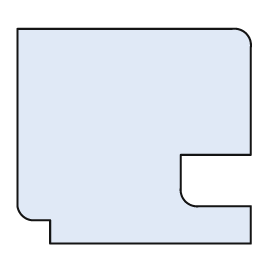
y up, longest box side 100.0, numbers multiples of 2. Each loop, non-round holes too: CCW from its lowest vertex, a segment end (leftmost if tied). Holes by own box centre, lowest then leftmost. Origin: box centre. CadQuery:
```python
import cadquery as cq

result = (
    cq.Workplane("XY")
    .moveTo(-36.0, -46.0)
    .lineTo(50.0, -46.0)
    .lineTo(50.0, -30.0)
    .lineTo(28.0, -30.0)
    .threePointArc((22.0, -28.0), (20.0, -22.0))
    .lineTo(20.0, -8.0)
    .lineTo(50.0, -8.0)
    .lineTo(50.0, 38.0)
    .threePointArc((48.0, 44.0), (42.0, 46.0))
    .lineTo(-50.0, 46.0)
    .lineTo(-50.0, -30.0)
    .threePointArc((-48.0, -34.0), (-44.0, -36.0))
    .lineTo(-36.0, -36.0)
    .close()
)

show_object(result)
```